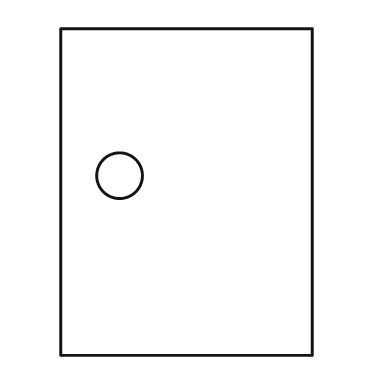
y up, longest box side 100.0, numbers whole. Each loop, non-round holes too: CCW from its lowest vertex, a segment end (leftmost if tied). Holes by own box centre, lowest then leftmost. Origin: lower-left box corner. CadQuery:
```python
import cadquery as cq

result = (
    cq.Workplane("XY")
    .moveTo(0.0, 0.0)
    .lineTo(77.0, 0.0)
    .lineTo(77.0, 100.0)
    .lineTo(0.0, 100.0)
    .close()
    .moveTo(18.0, 55.0)
    .circle(7.0)
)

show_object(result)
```